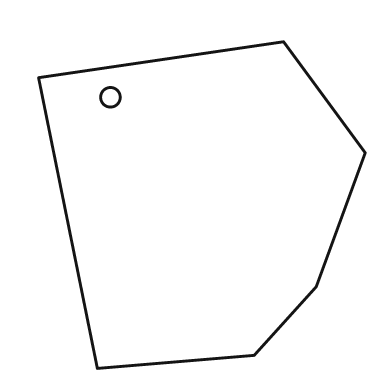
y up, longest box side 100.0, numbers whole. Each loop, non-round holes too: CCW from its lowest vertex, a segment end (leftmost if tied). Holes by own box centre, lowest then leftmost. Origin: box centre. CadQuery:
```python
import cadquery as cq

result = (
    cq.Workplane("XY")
    .moveTo(-32.0, -50.0)
    .lineTo(16.0, -46.0)
    .lineTo(35.0, -25.0)
    .lineTo(50.0, 16.0)
    .lineTo(25.0, 50.0)
    .lineTo(-50.0, 39.0)
    .close()
    .moveTo(-28.0, 33.0)
    .circle(3.0)
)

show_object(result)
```